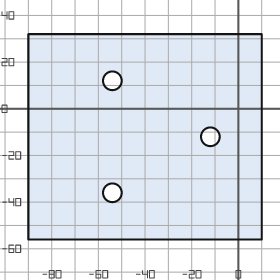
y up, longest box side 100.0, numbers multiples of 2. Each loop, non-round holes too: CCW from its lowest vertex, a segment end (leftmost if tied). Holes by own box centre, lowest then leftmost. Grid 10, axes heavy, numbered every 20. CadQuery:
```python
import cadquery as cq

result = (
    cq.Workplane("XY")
    .moveTo(-90.0, -56.0)
    .lineTo(10.0, -56.0)
    .lineTo(10.0, 32.0)
    .lineTo(-90.0, 32.0)
    .close()
    .moveTo(-54.0, -36.0)
    .circle(4.0)
    .moveTo(-12.0, -12.0)
    .circle(4.0)
    .moveTo(-54.0, 12.0)
    .circle(4.0)
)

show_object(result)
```